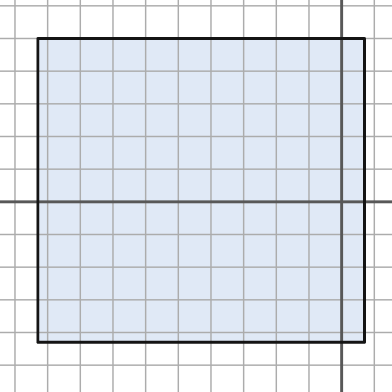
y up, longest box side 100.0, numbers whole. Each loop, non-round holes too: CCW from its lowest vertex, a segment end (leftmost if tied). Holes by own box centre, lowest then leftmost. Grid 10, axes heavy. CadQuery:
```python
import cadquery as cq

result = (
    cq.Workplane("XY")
    .moveTo(-93.0, -43.0)
    .lineTo(7.0, -43.0)
    .lineTo(7.0, 50.0)
    .lineTo(-93.0, 50.0)
    .close()
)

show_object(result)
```